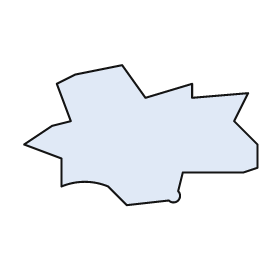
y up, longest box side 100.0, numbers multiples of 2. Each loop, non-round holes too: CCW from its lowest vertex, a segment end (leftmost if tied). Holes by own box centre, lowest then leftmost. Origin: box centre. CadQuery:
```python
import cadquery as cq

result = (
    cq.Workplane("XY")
    .moveTo(-6.0, -30.0)
    .lineTo(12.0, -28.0)
    .threePointArc((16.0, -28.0), (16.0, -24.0))
    .lineTo(18.0, -16.0)
    .lineTo(44.0, -16.0)
    .lineTo(50.0, -14.0)
    .lineTo(50.0, -4.0)
    .lineTo(40.0, 6.0)
    .lineTo(46.0, 18.0)
    .lineTo(22.0, 16.0)
    .lineTo(22.0, 22.0)
    .lineTo(2.0, 16.0)
    .lineTo(-8.0, 30.0)
    .lineTo(-28.0, 26.0)
    .lineTo(-36.0, 22.0)
    .lineTo(-30.0, 6.0)
    .lineTo(-38.0, 4.0)
    .lineTo(-50.0, -4.0)
    .lineTo(-34.0, -10.0)
    .lineTo(-34.0, -22.0)
    .threePointArc((-24.0, -20.0), (-14.0, -22.0))
    .close()
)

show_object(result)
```